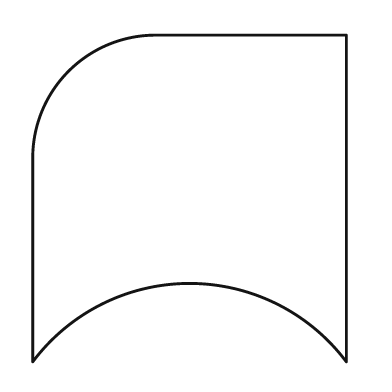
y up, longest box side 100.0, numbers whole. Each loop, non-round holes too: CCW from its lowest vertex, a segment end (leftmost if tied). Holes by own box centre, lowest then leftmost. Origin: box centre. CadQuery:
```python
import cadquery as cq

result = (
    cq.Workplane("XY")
    .moveTo(-48.0, -50.0)
    .threePointArc((0.0, -26.0), (48.0, -50.0))
    .lineTo(48.0, 50.0)
    .lineTo(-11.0, 50.0)
    .threePointArc((-37.0, 39.0), (-48.0, 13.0))
    .close()
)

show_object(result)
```